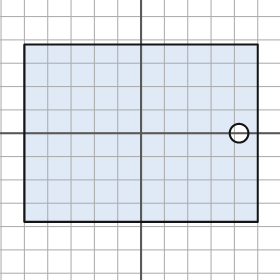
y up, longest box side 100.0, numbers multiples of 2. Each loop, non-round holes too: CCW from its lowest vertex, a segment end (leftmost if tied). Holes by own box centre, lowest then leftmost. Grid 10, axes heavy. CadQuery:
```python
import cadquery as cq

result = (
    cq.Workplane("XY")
    .moveTo(-50.0, -38.0)
    .lineTo(50.0, -38.0)
    .lineTo(50.0, 38.0)
    .lineTo(-50.0, 38.0)
    .close()
    .moveTo(42.0, 0.0)
    .circle(4.0)
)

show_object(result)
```